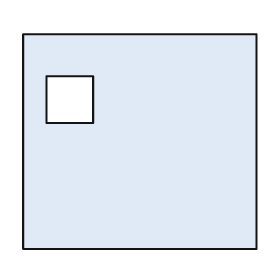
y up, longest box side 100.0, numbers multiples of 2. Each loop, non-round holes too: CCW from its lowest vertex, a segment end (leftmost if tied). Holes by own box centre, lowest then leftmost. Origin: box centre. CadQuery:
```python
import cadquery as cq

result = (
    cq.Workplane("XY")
    .moveTo(-50.0, -46.0)
    .lineTo(50.0, -46.0)
    .lineTo(50.0, 46.0)
    .lineTo(-50.0, 46.0)
    .close()
    .moveTo(-40.0, 8.0)
    .lineTo(-20.0, 8.0)
    .lineTo(-20.0, 28.0)
    .lineTo(-40.0, 28.0)
    .close()
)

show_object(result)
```